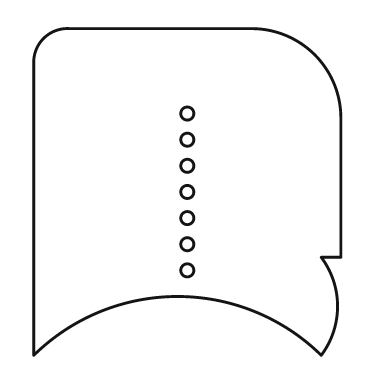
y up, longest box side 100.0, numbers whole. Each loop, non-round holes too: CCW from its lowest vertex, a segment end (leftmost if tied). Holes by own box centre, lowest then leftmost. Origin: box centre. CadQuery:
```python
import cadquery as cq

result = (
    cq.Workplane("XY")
    .moveTo(-47.0, -50.0)
    .threePointArc((-3.0, -32.0), (41.0, -50.0))
    .threePointArc((46.0, -35.0), (41.0, -20.0))
    .lineTo(47.0, -20.0)
    .lineTo(47.0, 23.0)
    .threePointArc((39.0, 42.0), (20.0, 50.0))
    .lineTo(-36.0, 50.0)
    .threePointArc((-44.0, 47.0), (-47.0, 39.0))
    .close()
    .moveTo(0.0, -24.0)
    .circle(2.0)
    .moveTo(0.0, -16.0)
    .circle(2.0)
    .moveTo(0.0, -8.0)
    .circle(2.0)
    .moveTo(0.0, 0.0)
    .circle(2.0)
    .moveTo(0.0, 8.0)
    .circle(2.0)
    .moveTo(0.0, 16.0)
    .circle(2.0)
    .moveTo(0.0, 24.0)
    .circle(2.0)
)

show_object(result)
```